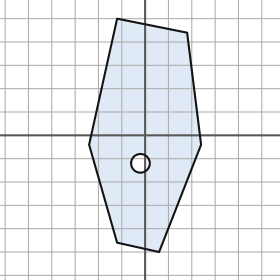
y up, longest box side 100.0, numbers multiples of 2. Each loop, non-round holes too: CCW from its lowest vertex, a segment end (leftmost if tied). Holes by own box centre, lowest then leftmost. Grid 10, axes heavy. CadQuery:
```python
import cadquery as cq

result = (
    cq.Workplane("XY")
    .moveTo(6.0, -50.0)
    .lineTo(24.0, -4.0)
    .lineTo(18.0, 44.0)
    .lineTo(-12.0, 50.0)
    .lineTo(-24.0, -4.0)
    .lineTo(-12.0, -46.0)
    .close()
    .moveTo(-2.0, -12.0)
    .circle(4.0)
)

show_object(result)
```